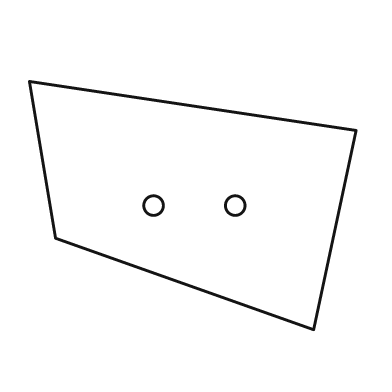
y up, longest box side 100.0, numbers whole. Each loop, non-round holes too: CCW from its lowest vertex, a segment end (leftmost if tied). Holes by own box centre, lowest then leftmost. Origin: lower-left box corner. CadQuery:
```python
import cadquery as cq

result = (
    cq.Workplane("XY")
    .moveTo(87.0, 0.0)
    .lineTo(100.0, 61.0)
    .lineTo(0.0, 76.0)
    .lineTo(8.0, 28.0)
    .close()
    .moveTo(38.0, 38.0)
    .circle(3.0)
    .moveTo(63.0, 38.0)
    .circle(3.0)
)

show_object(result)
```